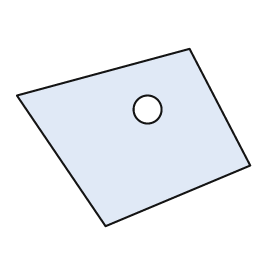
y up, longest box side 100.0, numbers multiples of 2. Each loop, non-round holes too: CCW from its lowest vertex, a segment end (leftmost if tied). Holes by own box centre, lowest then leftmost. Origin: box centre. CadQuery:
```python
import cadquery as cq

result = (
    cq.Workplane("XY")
    .moveTo(-12.0, -38.0)
    .lineTo(50.0, -12.0)
    .lineTo(24.0, 38.0)
    .lineTo(-50.0, 18.0)
    .close()
    .moveTo(6.0, 12.0)
    .circle(6.0)
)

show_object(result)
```